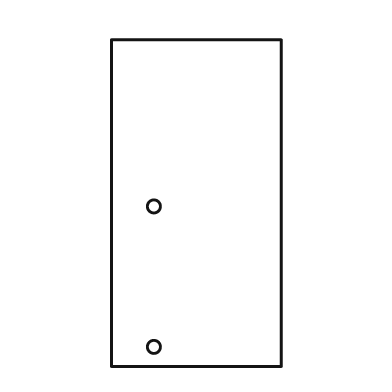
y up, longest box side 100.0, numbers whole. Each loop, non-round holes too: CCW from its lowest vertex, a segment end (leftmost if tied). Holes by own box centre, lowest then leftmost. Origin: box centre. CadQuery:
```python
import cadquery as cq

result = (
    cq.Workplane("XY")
    .moveTo(-26.0, -50.0)
    .lineTo(26.0, -50.0)
    .lineTo(26.0, 50.0)
    .lineTo(-26.0, 50.0)
    .close()
    .moveTo(-13.0, -44.0)
    .circle(2.0)
    .moveTo(-13.0, -1.0)
    .circle(2.0)
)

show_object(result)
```